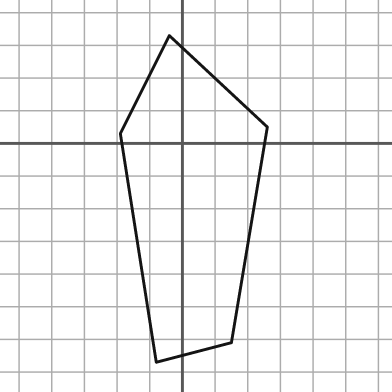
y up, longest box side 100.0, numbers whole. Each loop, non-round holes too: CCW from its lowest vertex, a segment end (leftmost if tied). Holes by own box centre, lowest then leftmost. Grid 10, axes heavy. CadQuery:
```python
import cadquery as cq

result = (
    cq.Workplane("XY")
    .moveTo(-8.0, -67.0)
    .lineTo(15.0, -61.0)
    .lineTo(26.0, 5.0)
    .lineTo(-4.0, 33.0)
    .lineTo(-19.0, 3.0)
    .close()
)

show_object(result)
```